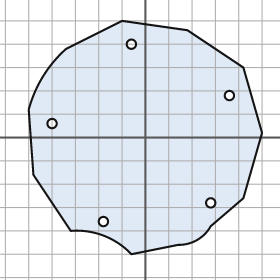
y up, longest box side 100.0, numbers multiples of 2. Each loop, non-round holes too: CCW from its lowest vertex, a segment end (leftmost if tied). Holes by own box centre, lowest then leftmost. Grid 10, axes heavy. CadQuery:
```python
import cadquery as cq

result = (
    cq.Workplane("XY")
    .moveTo(-6.0, -50.0)
    .lineTo(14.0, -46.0)
    .threePointArc((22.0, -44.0), (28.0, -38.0))
    .lineTo(42.0, -26.0)
    .lineTo(50.0, 2.0)
    .lineTo(42.0, 30.0)
    .lineTo(18.0, 46.0)
    .lineTo(-10.0, 50.0)
    .lineTo(-34.0, 38.0)
    .threePointArc((-44.0, 26.0), (-50.0, 12.0))
    .lineTo(-48.0, -16.0)
    .lineTo(-32.0, -40.0)
    .threePointArc((-18.0, -42.0), (-6.0, -50.0))
    .close()
    .moveTo(-18.0, -36.0)
    .circle(2.0)
    .moveTo(28.0, -28.0)
    .circle(2.0)
    .moveTo(-40.0, 6.0)
    .circle(2.0)
    .moveTo(36.0, 18.0)
    .circle(2.0)
    .moveTo(-6.0, 40.0)
    .circle(2.0)
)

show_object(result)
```